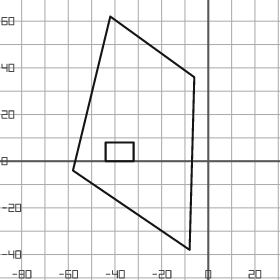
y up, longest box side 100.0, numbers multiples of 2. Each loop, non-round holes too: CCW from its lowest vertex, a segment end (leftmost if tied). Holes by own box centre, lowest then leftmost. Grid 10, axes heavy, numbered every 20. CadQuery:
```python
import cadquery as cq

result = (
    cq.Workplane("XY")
    .moveTo(-8.0, -38.0)
    .lineTo(-6.0, 36.0)
    .lineTo(-42.0, 62.0)
    .lineTo(-58.0, -4.0)
    .close()
    .moveTo(-44.0, 0.0)
    .lineTo(-32.0, 0.0)
    .lineTo(-32.0, 8.0)
    .lineTo(-44.0, 8.0)
    .close()
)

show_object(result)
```